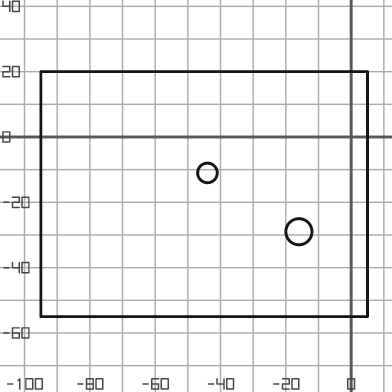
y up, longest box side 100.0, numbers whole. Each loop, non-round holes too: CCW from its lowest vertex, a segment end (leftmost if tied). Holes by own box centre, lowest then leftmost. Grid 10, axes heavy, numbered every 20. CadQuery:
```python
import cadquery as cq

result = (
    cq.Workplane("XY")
    .moveTo(-95.0, -55.0)
    .lineTo(5.0, -55.0)
    .lineTo(5.0, 20.0)
    .lineTo(-95.0, 20.0)
    .close()
    .moveTo(-16.0, -29.0)
    .circle(4.0)
    .moveTo(-44.0, -11.0)
    .circle(3.0)
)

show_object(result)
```